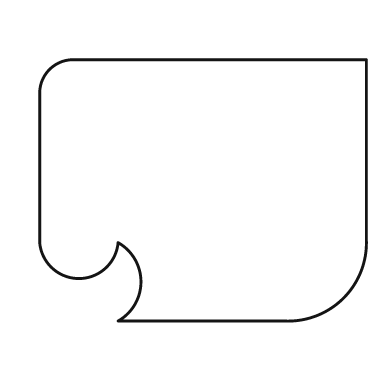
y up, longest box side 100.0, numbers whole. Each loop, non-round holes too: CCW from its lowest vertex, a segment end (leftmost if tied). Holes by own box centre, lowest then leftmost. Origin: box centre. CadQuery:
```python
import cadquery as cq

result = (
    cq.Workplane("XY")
    .moveTo(-26.0, -40.0)
    .lineTo(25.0, -40.0)
    .threePointArc((43.0, -33.0), (50.0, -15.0))
    .lineTo(50.0, 40.0)
    .lineTo(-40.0, 40.0)
    .threePointArc((-47.0, 37.0), (-50.0, 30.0))
    .lineTo(-50.0, -16.0)
    .threePointArc((-38.0, -27.0), (-26.0, -16.0))
    .threePointArc((-19.0, -28.0), (-26.0, -40.0))
    .close()
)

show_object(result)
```